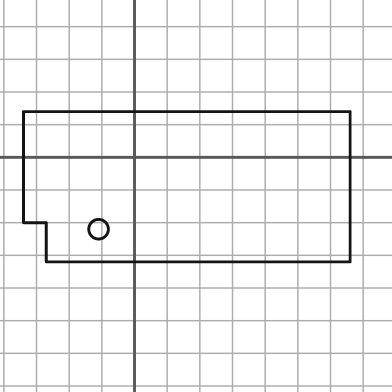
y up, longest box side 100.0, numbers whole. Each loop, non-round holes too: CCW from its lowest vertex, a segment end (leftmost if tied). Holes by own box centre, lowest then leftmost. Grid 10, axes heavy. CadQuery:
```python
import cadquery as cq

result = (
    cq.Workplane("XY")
    .moveTo(-27.0, -32.0)
    .lineTo(66.0, -32.0)
    .lineTo(66.0, 14.0)
    .lineTo(-34.0, 14.0)
    .lineTo(-34.0, -20.0)
    .lineTo(-27.0, -20.0)
    .close()
    .moveTo(-11.0, -22.0)
    .circle(3.0)
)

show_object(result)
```